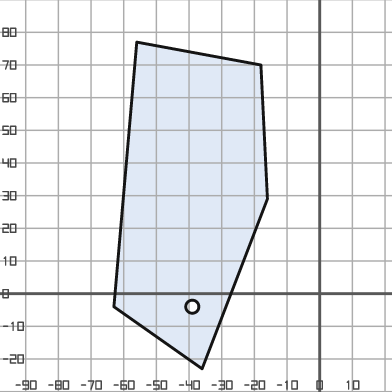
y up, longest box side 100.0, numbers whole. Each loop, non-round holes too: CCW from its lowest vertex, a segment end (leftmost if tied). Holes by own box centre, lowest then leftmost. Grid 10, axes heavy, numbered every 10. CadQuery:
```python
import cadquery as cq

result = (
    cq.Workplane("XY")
    .moveTo(-36.0, -23.0)
    .lineTo(-16.0, 29.0)
    .lineTo(-18.0, 70.0)
    .lineTo(-56.0, 77.0)
    .lineTo(-63.0, -4.0)
    .close()
    .moveTo(-39.0, -4.0)
    .circle(2.0)
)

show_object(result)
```